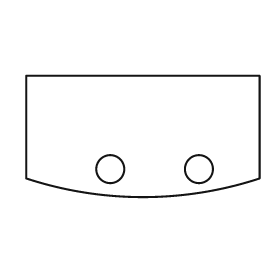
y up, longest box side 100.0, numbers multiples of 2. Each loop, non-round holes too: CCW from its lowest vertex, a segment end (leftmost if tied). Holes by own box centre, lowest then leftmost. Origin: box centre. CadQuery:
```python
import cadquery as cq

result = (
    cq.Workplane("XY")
    .moveTo(-50.0, -18.0)
    .threePointArc((0.0, -26.0), (50.0, -18.0))
    .lineTo(50.0, 26.0)
    .lineTo(-50.0, 26.0)
    .close()
    .moveTo(-14.0, -14.0)
    .circle(6.0)
    .moveTo(24.0, -14.0)
    .circle(6.0)
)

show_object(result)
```